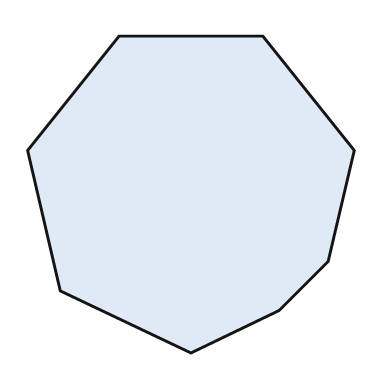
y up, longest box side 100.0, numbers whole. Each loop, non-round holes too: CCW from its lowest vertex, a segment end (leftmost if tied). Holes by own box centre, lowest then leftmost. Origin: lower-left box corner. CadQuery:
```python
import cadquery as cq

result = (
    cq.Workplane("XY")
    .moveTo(50.0, 0.0)
    .lineTo(77.0, 13.0)
    .lineTo(92.0, 28.0)
    .lineTo(100.0, 62.0)
    .lineTo(72.0, 97.0)
    .lineTo(28.0, 97.0)
    .lineTo(0.0, 62.0)
    .lineTo(10.0, 19.0)
    .close()
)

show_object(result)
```